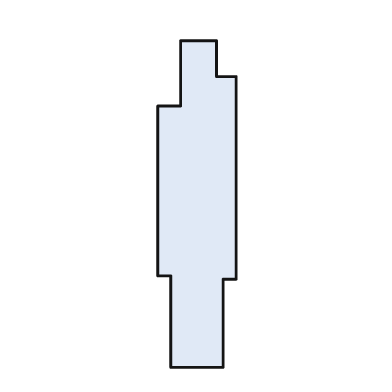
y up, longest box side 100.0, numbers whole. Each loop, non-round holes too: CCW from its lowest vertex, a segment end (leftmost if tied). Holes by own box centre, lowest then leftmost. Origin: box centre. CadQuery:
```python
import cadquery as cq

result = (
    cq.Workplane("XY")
    .moveTo(-8.0, -50.0)
    .lineTo(8.0, -50.0)
    .lineTo(8.0, -23.0)
    .lineTo(12.0, -23.0)
    .lineTo(12.0, 39.0)
    .lineTo(6.0, 39.0)
    .lineTo(6.0, 50.0)
    .lineTo(-5.0, 50.0)
    .lineTo(-5.0, 30.0)
    .lineTo(-12.0, 30.0)
    .lineTo(-12.0, -22.0)
    .lineTo(-8.0, -22.0)
    .close()
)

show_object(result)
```